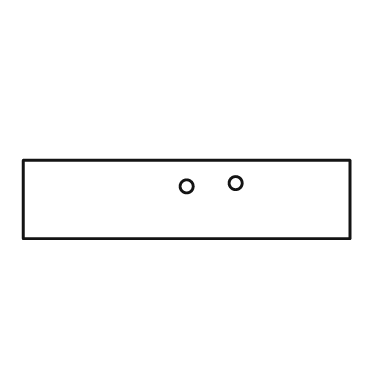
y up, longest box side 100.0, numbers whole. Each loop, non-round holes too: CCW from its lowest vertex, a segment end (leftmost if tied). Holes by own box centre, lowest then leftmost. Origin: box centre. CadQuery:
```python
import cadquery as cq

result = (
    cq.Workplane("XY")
    .moveTo(-50.0, -12.0)
    .lineTo(50.0, -12.0)
    .lineTo(50.0, 12.0)
    .lineTo(-50.0, 12.0)
    .close()
    .moveTo(0.0, 4.0)
    .circle(2.0)
    .moveTo(15.0, 5.0)
    .circle(2.0)
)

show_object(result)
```